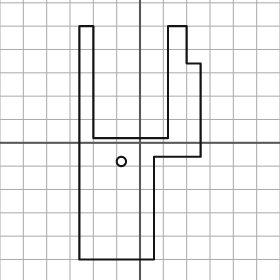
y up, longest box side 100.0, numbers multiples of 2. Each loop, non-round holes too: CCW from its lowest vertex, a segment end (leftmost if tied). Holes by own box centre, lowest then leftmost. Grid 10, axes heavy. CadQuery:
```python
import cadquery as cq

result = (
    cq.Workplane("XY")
    .moveTo(-26.0, -50.0)
    .lineTo(6.0, -50.0)
    .lineTo(6.0, -6.0)
    .lineTo(26.0, -6.0)
    .lineTo(26.0, 34.0)
    .lineTo(20.0, 34.0)
    .lineTo(20.0, 50.0)
    .lineTo(12.0, 50.0)
    .lineTo(12.0, 2.0)
    .lineTo(-20.0, 2.0)
    .lineTo(-20.0, 50.0)
    .lineTo(-26.0, 50.0)
    .close()
    .moveTo(-8.0, -8.0)
    .circle(2.0)
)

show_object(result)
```